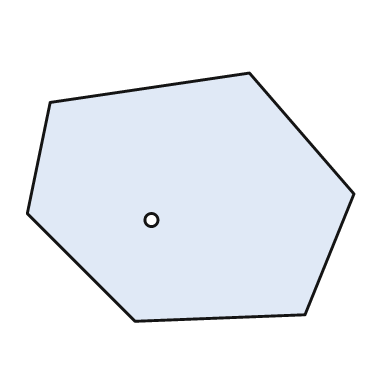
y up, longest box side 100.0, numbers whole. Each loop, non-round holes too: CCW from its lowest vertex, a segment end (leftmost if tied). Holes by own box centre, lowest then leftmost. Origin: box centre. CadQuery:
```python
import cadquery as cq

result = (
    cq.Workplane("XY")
    .moveTo(-17.0, -38.0)
    .lineTo(35.0, -36.0)
    .lineTo(50.0, 1.0)
    .lineTo(18.0, 38.0)
    .lineTo(-43.0, 29.0)
    .lineTo(-50.0, -5.0)
    .close()
    .moveTo(-12.0, -7.0)
    .circle(2.0)
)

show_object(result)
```